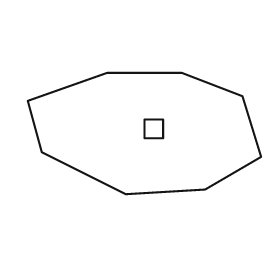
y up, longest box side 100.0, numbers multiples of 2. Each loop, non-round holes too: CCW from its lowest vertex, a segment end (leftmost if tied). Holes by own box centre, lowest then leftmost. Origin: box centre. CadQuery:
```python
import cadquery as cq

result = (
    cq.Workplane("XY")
    .moveTo(-8.0, -26.0)
    .lineTo(26.0, -24.0)
    .lineTo(50.0, -10.0)
    .lineTo(42.0, 16.0)
    .lineTo(16.0, 26.0)
    .lineTo(-16.0, 26.0)
    .lineTo(-50.0, 14.0)
    .lineTo(-44.0, -8.0)
    .close()
    .moveTo(0.0, -2.0)
    .lineTo(8.0, -2.0)
    .lineTo(8.0, 6.0)
    .lineTo(0.0, 6.0)
    .close()
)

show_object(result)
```